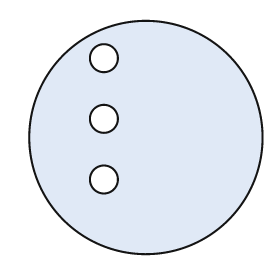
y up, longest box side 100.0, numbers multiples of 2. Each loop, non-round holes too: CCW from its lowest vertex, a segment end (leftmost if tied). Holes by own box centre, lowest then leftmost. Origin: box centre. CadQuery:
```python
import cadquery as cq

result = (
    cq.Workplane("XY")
    .moveTo(0.0, 0.0)
    .circle(50.0)
    .moveTo(-18.0, -18.0)
    .circle(6.0)
    .moveTo(-18.0, 8.0)
    .circle(6.0)
    .moveTo(-18.0, 34.0)
    .circle(6.0)
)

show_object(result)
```